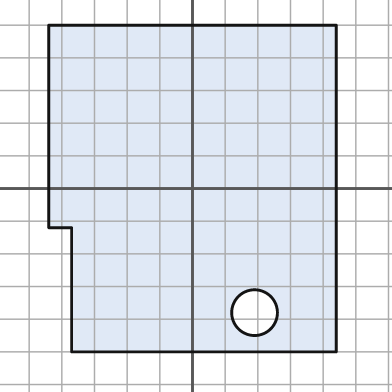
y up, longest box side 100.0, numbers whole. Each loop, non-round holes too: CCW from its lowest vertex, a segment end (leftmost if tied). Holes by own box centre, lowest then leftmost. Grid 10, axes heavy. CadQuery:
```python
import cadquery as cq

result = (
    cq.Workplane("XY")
    .moveTo(-37.0, -50.0)
    .lineTo(44.0, -50.0)
    .lineTo(44.0, 50.0)
    .lineTo(-44.0, 50.0)
    .lineTo(-44.0, -12.0)
    .lineTo(-37.0, -12.0)
    .close()
    .moveTo(19.0, -38.0)
    .circle(7.0)
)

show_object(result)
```